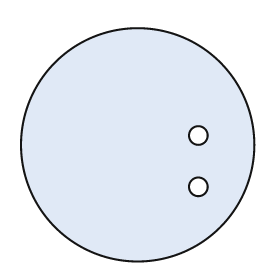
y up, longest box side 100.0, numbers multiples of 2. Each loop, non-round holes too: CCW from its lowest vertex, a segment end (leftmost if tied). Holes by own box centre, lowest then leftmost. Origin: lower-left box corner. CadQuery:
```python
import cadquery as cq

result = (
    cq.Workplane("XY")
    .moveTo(50.0, 50.0)
    .circle(50.0)
    .moveTo(76.0, 32.0)
    .circle(4.0)
    .moveTo(76.0, 54.0)
    .circle(4.0)
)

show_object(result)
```